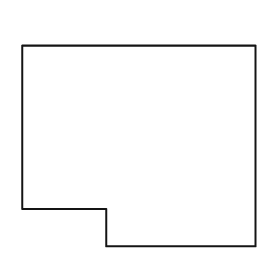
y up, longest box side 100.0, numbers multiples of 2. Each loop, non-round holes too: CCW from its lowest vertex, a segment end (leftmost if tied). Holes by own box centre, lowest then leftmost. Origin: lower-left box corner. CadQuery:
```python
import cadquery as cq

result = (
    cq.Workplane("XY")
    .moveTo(36.0, 0.0)
    .lineTo(100.0, 0.0)
    .lineTo(100.0, 86.0)
    .lineTo(0.0, 86.0)
    .lineTo(0.0, 16.0)
    .lineTo(36.0, 16.0)
    .close()
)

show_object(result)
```